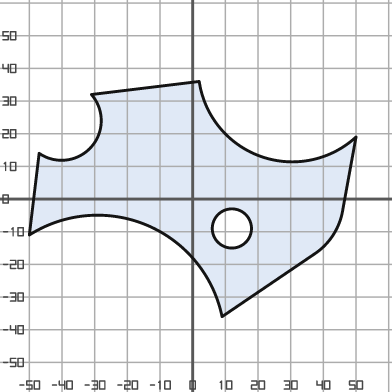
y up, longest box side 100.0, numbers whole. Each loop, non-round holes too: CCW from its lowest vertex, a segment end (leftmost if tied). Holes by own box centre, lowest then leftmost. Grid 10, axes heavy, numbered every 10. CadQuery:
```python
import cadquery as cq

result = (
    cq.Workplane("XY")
    .moveTo(9.0, -36.0)
    .lineTo(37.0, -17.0)
    .threePointArc((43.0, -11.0), (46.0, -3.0))
    .lineTo(50.0, 19.0)
    .threePointArc((21.0, 13.0), (2.0, 36.0))
    .lineTo(-31.0, 32.0)
    .threePointArc((-31.0, 16.0), (-47.0, 14.0))
    .lineTo(-50.0, -11.0)
    .threePointArc((-14.0, -8.0), (9.0, -36.0))
    .close()
    .moveTo(12.0, -9.0)
    .circle(6.0)
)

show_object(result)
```